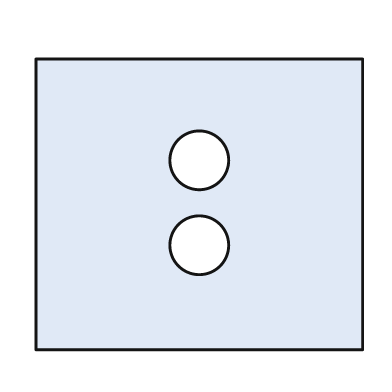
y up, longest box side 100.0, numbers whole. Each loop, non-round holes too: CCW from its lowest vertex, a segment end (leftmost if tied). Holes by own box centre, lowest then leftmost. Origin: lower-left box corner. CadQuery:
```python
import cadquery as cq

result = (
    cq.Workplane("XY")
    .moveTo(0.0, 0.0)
    .lineTo(100.0, 0.0)
    .lineTo(100.0, 89.0)
    .lineTo(0.0, 89.0)
    .close()
    .moveTo(50.0, 32.0)
    .circle(9.0)
    .moveTo(50.0, 58.0)
    .circle(9.0)
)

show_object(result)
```